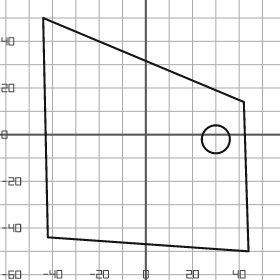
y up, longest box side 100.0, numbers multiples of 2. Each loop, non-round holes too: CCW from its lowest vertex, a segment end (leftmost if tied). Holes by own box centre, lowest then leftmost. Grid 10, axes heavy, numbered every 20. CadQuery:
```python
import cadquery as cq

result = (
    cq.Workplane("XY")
    .moveTo(44.0, -50.0)
    .lineTo(42.0, 14.0)
    .lineTo(-44.0, 50.0)
    .lineTo(-42.0, -44.0)
    .close()
    .moveTo(30.0, -2.0)
    .circle(6.0)
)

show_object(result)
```